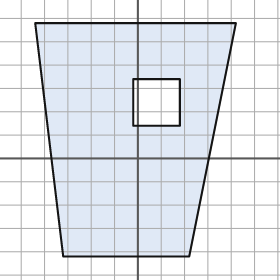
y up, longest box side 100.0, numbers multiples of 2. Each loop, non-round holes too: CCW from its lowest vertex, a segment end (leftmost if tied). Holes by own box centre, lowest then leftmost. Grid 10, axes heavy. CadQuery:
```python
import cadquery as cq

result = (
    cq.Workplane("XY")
    .moveTo(-32.0, -42.0)
    .lineTo(22.0, -42.0)
    .lineTo(42.0, 58.0)
    .lineTo(-44.0, 58.0)
    .close()
    .moveTo(-2.0, 14.0)
    .lineTo(18.0, 14.0)
    .lineTo(18.0, 34.0)
    .lineTo(-2.0, 34.0)
    .close()
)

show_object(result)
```